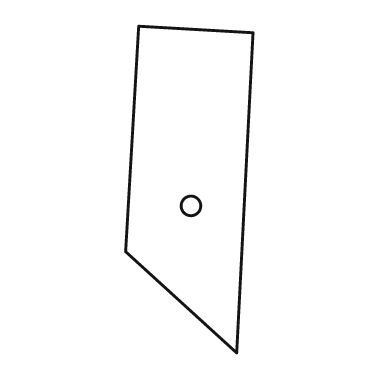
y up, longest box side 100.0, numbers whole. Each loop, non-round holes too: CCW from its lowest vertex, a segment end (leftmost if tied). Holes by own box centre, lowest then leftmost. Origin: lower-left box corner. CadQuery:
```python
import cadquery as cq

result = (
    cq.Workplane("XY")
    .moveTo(34.0, 0.0)
    .lineTo(39.0, 98.0)
    .lineTo(4.0, 100.0)
    .lineTo(0.0, 31.0)
    .close()
    .moveTo(20.0, 45.0)
    .circle(3.0)
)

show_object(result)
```